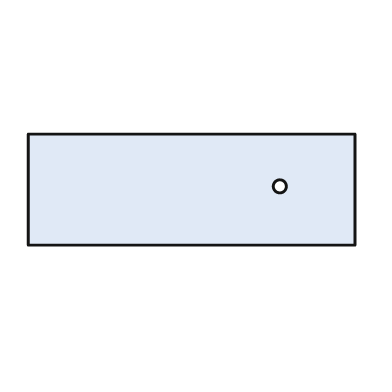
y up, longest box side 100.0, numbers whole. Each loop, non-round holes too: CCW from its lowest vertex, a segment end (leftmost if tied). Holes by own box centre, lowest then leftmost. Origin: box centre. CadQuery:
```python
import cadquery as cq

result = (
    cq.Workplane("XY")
    .moveTo(-50.0, -17.0)
    .lineTo(50.0, -17.0)
    .lineTo(50.0, 17.0)
    .lineTo(-50.0, 17.0)
    .close()
    .moveTo(27.0, 1.0)
    .circle(2.0)
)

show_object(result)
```